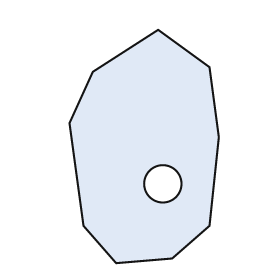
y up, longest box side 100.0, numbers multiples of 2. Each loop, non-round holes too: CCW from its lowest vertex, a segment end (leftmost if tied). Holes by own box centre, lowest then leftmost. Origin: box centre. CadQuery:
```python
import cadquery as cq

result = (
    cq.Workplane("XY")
    .moveTo(-12.0, -50.0)
    .lineTo(12.0, -48.0)
    .lineTo(28.0, -34.0)
    .lineTo(32.0, 4.0)
    .lineTo(28.0, 34.0)
    .lineTo(6.0, 50.0)
    .lineTo(-22.0, 32.0)
    .lineTo(-32.0, 10.0)
    .lineTo(-26.0, -34.0)
    .close()
    .moveTo(8.0, -16.0)
    .circle(8.0)
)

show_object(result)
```